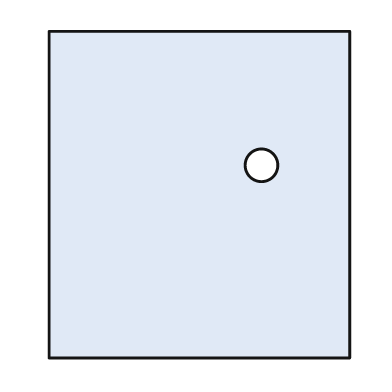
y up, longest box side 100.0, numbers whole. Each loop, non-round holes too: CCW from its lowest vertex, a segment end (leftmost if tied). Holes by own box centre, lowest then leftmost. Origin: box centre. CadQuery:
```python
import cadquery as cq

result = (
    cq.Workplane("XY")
    .moveTo(-46.0, -50.0)
    .lineTo(46.0, -50.0)
    .lineTo(46.0, 50.0)
    .lineTo(-46.0, 50.0)
    .close()
    .moveTo(19.0, 9.0)
    .circle(5.0)
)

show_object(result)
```